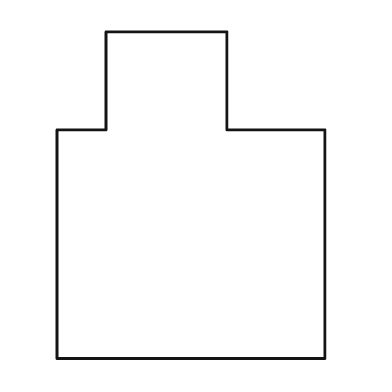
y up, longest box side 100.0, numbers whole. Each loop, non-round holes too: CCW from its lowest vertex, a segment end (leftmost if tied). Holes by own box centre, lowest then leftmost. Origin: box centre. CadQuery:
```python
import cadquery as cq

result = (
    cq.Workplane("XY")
    .moveTo(-41.0, -50.0)
    .lineTo(41.0, -50.0)
    .lineTo(41.0, 20.0)
    .lineTo(11.0, 20.0)
    .lineTo(11.0, 50.0)
    .lineTo(-26.0, 50.0)
    .lineTo(-26.0, 20.0)
    .lineTo(-41.0, 20.0)
    .close()
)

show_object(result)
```